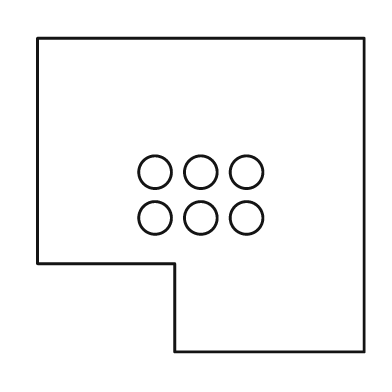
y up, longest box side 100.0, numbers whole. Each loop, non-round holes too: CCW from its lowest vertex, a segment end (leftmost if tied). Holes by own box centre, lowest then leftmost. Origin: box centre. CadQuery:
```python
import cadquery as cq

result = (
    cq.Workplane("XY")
    .moveTo(-8.0, -48.0)
    .lineTo(50.0, -48.0)
    .lineTo(50.0, 48.0)
    .lineTo(-50.0, 48.0)
    .lineTo(-50.0, -21.0)
    .lineTo(-8.0, -21.0)
    .close()
    .moveTo(-14.0, -7.0)
    .circle(5.0)
    .moveTo(0.0, -7.0)
    .circle(5.0)
    .moveTo(14.0, -7.0)
    .circle(5.0)
    .moveTo(-14.0, 7.0)
    .circle(5.0)
    .moveTo(0.0, 7.0)
    .circle(5.0)
    .moveTo(14.0, 7.0)
    .circle(5.0)
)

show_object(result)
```